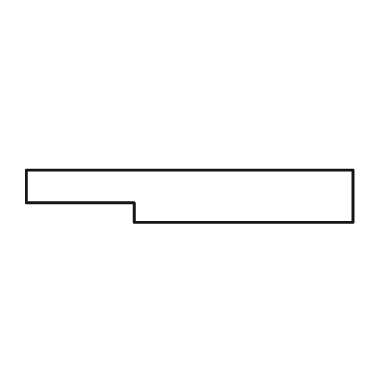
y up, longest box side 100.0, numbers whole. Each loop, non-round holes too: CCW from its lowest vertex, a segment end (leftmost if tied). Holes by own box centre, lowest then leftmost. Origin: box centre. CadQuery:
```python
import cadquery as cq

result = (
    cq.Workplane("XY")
    .moveTo(-17.0, -8.0)
    .lineTo(50.0, -8.0)
    .lineTo(50.0, 8.0)
    .lineTo(-50.0, 8.0)
    .lineTo(-50.0, -2.0)
    .lineTo(-17.0, -2.0)
    .close()
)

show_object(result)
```